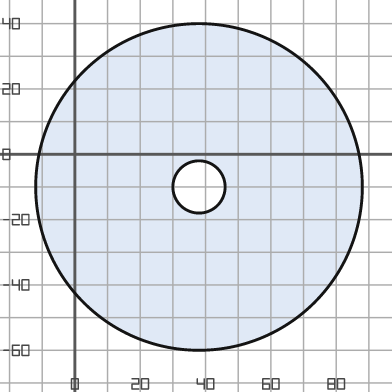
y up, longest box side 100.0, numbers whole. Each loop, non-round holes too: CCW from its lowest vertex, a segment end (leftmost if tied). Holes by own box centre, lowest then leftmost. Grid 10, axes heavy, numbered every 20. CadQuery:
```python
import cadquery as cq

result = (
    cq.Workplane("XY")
    .moveTo(38.0, -10.0)
    .circle(50.0)
    .moveTo(38.0, -10.0)
    .circle(8.0)
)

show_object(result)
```